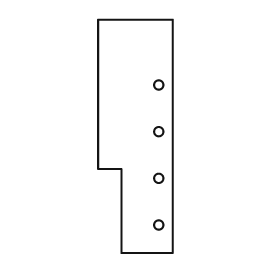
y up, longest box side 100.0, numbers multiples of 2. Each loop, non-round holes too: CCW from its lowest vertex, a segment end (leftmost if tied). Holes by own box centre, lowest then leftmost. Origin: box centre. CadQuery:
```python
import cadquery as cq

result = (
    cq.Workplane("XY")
    .moveTo(-6.0, -50.0)
    .lineTo(16.0, -50.0)
    .lineTo(16.0, 50.0)
    .lineTo(-16.0, 50.0)
    .lineTo(-16.0, -14.0)
    .lineTo(-6.0, -14.0)
    .close()
    .moveTo(10.0, -38.0)
    .circle(2.0)
    .moveTo(10.0, -18.0)
    .circle(2.0)
    .moveTo(10.0, 2.0)
    .circle(2.0)
    .moveTo(10.0, 22.0)
    .circle(2.0)
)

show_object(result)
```